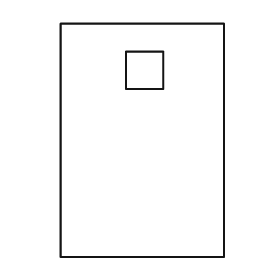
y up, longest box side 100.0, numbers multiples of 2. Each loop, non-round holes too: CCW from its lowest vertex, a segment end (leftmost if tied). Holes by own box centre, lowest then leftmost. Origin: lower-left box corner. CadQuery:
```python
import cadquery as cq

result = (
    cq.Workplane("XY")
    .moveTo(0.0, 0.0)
    .lineTo(70.0, 0.0)
    .lineTo(70.0, 100.0)
    .lineTo(0.0, 100.0)
    .close()
    .moveTo(28.0, 72.0)
    .lineTo(44.0, 72.0)
    .lineTo(44.0, 88.0)
    .lineTo(28.0, 88.0)
    .close()
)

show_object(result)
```